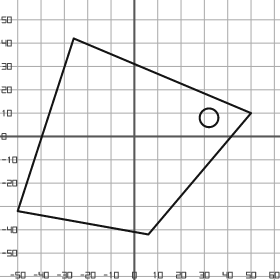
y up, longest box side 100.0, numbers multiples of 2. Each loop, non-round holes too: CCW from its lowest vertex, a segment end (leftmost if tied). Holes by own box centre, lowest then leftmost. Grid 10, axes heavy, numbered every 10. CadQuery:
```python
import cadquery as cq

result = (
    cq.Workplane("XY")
    .moveTo(6.0, -42.0)
    .lineTo(50.0, 10.0)
    .lineTo(-26.0, 42.0)
    .lineTo(-50.0, -32.0)
    .close()
    .moveTo(32.0, 8.0)
    .circle(4.0)
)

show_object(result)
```